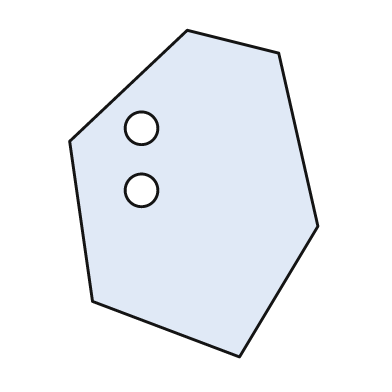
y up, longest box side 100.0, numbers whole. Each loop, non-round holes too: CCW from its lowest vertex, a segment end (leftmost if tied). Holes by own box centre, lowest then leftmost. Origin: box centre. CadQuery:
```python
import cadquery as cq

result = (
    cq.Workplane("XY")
    .moveTo(14.0, -50.0)
    .lineTo(38.0, -10.0)
    .lineTo(26.0, 43.0)
    .lineTo(-2.0, 50.0)
    .lineTo(-38.0, 16.0)
    .lineTo(-31.0, -33.0)
    .close()
    .moveTo(-16.0, 1.0)
    .circle(5.0)
    .moveTo(-16.0, 20.0)
    .circle(5.0)
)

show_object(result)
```